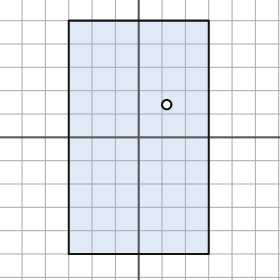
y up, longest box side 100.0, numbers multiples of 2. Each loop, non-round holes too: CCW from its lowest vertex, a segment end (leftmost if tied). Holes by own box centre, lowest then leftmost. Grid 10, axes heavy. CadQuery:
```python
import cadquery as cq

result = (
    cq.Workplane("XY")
    .moveTo(-30.0, -50.0)
    .lineTo(30.0, -50.0)
    .lineTo(30.0, 50.0)
    .lineTo(-30.0, 50.0)
    .close()
    .moveTo(12.0, 14.0)
    .circle(2.0)
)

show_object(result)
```